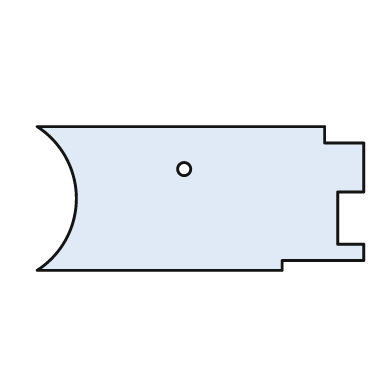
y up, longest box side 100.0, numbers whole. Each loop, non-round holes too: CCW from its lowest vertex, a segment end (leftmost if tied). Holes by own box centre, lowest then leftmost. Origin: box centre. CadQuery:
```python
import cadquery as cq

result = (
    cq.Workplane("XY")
    .moveTo(-50.0, -22.0)
    .lineTo(25.0, -22.0)
    .lineTo(25.0, -19.0)
    .lineTo(50.0, -19.0)
    .lineTo(50.0, -14.0)
    .lineTo(42.0, -14.0)
    .lineTo(42.0, 2.0)
    .lineTo(50.0, 2.0)
    .lineTo(50.0, 17.0)
    .lineTo(38.0, 17.0)
    .lineTo(38.0, 22.0)
    .lineTo(-50.0, 22.0)
    .threePointArc((-38.0, 0.0), (-50.0, -22.0))
    .close()
    .moveTo(-5.0, 9.0)
    .circle(2.0)
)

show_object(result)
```